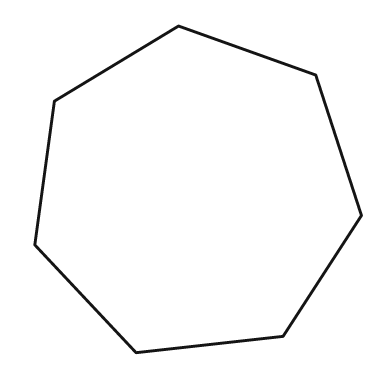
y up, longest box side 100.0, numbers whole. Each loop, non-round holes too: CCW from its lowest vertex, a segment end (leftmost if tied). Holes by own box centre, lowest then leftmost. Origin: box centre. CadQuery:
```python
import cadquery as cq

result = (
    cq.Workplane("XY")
    .moveTo(-19.0, -50.0)
    .lineTo(26.0, -45.0)
    .lineTo(50.0, -8.0)
    .lineTo(36.0, 35.0)
    .lineTo(-6.0, 50.0)
    .lineTo(-44.0, 27.0)
    .lineTo(-50.0, -17.0)
    .close()
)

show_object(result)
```